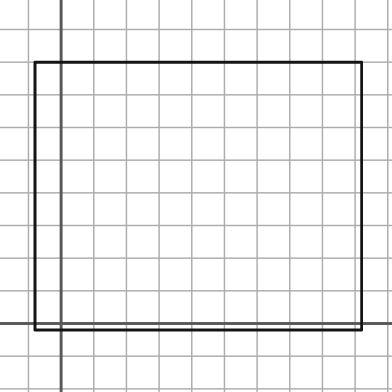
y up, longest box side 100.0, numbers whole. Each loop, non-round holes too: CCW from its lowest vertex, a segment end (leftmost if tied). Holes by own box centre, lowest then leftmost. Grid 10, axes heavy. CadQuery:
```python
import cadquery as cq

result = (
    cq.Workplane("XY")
    .moveTo(-8.0, -2.0)
    .lineTo(92.0, -2.0)
    .lineTo(92.0, 80.0)
    .lineTo(-8.0, 80.0)
    .close()
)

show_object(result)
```